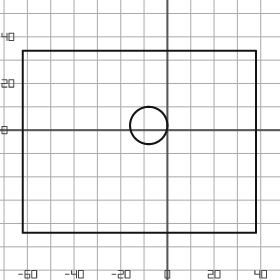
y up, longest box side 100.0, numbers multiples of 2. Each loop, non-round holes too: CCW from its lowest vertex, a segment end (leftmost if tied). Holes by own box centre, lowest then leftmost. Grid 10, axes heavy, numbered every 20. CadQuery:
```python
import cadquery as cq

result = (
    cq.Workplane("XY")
    .moveTo(-62.0, -44.0)
    .lineTo(38.0, -44.0)
    .lineTo(38.0, 34.0)
    .lineTo(-62.0, 34.0)
    .close()
    .moveTo(-8.0, 2.0)
    .circle(8.0)
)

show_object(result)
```